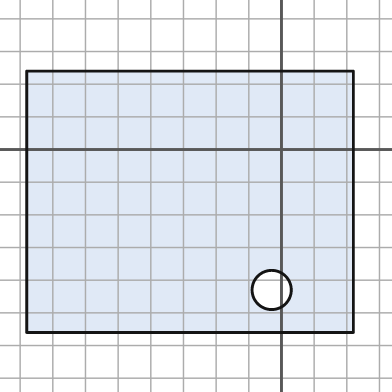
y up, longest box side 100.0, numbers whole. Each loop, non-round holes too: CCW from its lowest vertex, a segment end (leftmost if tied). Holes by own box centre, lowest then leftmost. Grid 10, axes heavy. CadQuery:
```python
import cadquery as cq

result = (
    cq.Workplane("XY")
    .moveTo(-78.0, -56.0)
    .lineTo(22.0, -56.0)
    .lineTo(22.0, 24.0)
    .lineTo(-78.0, 24.0)
    .close()
    .moveTo(-3.0, -43.0)
    .circle(6.0)
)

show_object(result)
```